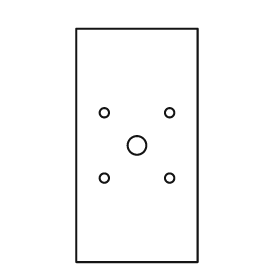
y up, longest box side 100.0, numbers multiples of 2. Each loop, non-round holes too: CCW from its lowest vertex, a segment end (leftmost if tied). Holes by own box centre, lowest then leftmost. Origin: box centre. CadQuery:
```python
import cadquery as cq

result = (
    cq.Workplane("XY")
    .moveTo(-26.0, -50.0)
    .lineTo(26.0, -50.0)
    .lineTo(26.0, 50.0)
    .lineTo(-26.0, 50.0)
    .close()
    .moveTo(-14.0, -14.0)
    .circle(2.0)
    .moveTo(14.0, -14.0)
    .circle(2.0)
    .moveTo(0.0, 0.0)
    .circle(4.0)
    .moveTo(-14.0, 14.0)
    .circle(2.0)
    .moveTo(14.0, 14.0)
    .circle(2.0)
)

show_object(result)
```